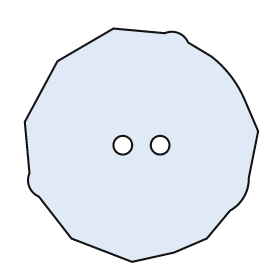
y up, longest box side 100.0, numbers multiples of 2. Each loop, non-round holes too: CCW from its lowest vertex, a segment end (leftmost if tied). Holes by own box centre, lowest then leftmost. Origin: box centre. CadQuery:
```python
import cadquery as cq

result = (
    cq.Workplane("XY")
    .moveTo(-4.0, -50.0)
    .lineTo(14.0, -46.0)
    .lineTo(28.0, -40.0)
    .lineTo(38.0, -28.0)
    .threePointArc((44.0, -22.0), (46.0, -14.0))
    .lineTo(50.0, 6.0)
    .lineTo(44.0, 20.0)
    .threePointArc((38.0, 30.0), (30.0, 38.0))
    .lineTo(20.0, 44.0)
    .threePointArc((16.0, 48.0), (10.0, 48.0))
    .lineTo(-12.0, 50.0)
    .lineTo(-36.0, 36.0)
    .lineTo(-50.0, 10.0)
    .lineTo(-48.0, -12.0)
    .threePointArc((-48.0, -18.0), (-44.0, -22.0))
    .lineTo(-30.0, -40.0)
    .close()
    .moveTo(-8.0, 0.0)
    .circle(4.0)
    .moveTo(8.0, 0.0)
    .circle(4.0)
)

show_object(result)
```